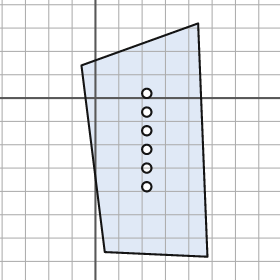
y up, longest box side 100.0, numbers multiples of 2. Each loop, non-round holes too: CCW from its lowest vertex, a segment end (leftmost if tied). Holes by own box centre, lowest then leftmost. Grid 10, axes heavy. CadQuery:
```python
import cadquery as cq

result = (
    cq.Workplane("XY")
    .moveTo(48.0, -68.0)
    .lineTo(44.0, 32.0)
    .lineTo(-6.0, 14.0)
    .lineTo(4.0, -66.0)
    .close()
    .moveTo(22.0, -38.0)
    .circle(2.0)
    .moveTo(22.0, -30.0)
    .circle(2.0)
    .moveTo(22.0, -22.0)
    .circle(2.0)
    .moveTo(22.0, -14.0)
    .circle(2.0)
    .moveTo(22.0, -6.0)
    .circle(2.0)
    .moveTo(22.0, 2.0)
    .circle(2.0)
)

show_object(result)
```